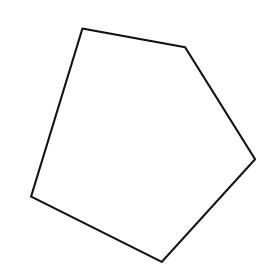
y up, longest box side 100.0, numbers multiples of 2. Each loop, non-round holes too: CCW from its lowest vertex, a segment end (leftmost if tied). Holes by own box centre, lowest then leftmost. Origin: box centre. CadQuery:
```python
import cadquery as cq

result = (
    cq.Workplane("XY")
    .moveTo(8.0, -50.0)
    .lineTo(48.0, -6.0)
    .lineTo(18.0, 42.0)
    .lineTo(-26.0, 50.0)
    .lineTo(-48.0, -22.0)
    .close()
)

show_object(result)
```